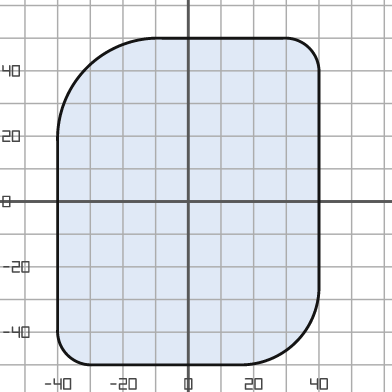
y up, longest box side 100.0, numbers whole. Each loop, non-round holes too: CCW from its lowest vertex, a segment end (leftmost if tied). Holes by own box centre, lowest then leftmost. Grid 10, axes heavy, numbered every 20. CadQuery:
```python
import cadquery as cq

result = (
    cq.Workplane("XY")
    .moveTo(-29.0, -50.0)
    .lineTo(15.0, -50.0)
    .threePointArc((33.0, -43.0), (40.0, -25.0))
    .lineTo(40.0, 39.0)
    .threePointArc((37.0, 47.0), (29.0, 50.0))
    .lineTo(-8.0, 50.0)
    .threePointArc((-31.0, 41.0), (-40.0, 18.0))
    .lineTo(-40.0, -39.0)
    .threePointArc((-37.0, -47.0), (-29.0, -50.0))
    .close()
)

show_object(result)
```